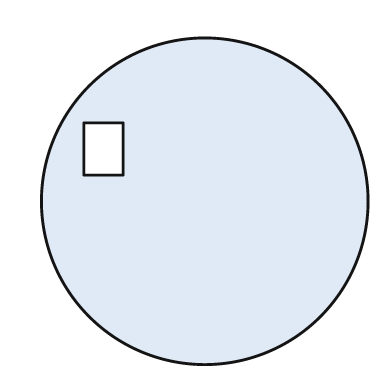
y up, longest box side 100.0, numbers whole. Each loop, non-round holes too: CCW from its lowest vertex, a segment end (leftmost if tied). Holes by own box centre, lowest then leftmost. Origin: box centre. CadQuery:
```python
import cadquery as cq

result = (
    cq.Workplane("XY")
    .moveTo(0.0, 0.0)
    .circle(50.0)
    .moveTo(-37.0, 8.0)
    .lineTo(-25.0, 8.0)
    .lineTo(-25.0, 24.0)
    .lineTo(-37.0, 24.0)
    .close()
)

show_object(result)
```